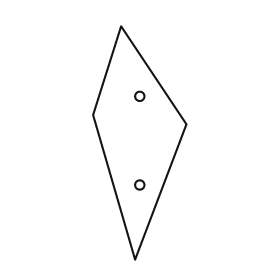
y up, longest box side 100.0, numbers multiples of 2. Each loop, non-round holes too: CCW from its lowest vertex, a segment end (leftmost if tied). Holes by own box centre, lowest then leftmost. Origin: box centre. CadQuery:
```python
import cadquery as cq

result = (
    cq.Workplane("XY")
    .moveTo(-2.0, -50.0)
    .lineTo(20.0, 8.0)
    .lineTo(-8.0, 50.0)
    .lineTo(-20.0, 12.0)
    .close()
    .moveTo(0.0, -18.0)
    .circle(2.0)
    .moveTo(0.0, 20.0)
    .circle(2.0)
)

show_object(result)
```